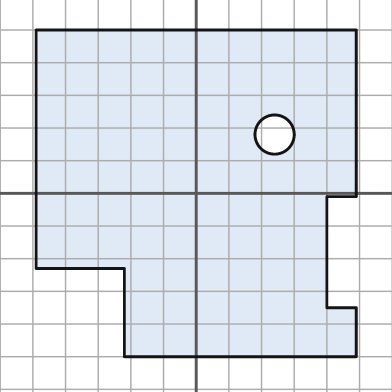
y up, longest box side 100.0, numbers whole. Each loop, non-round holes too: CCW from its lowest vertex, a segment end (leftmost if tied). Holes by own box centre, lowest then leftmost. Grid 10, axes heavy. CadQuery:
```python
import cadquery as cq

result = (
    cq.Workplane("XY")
    .moveTo(-22.0, -50.0)
    .lineTo(49.0, -50.0)
    .lineTo(49.0, -35.0)
    .lineTo(40.0, -35.0)
    .lineTo(40.0, -1.0)
    .lineTo(49.0, -1.0)
    .lineTo(49.0, 50.0)
    .lineTo(-49.0, 50.0)
    .lineTo(-49.0, -23.0)
    .lineTo(-22.0, -23.0)
    .close()
    .moveTo(24.0, 18.0)
    .circle(6.0)
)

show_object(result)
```